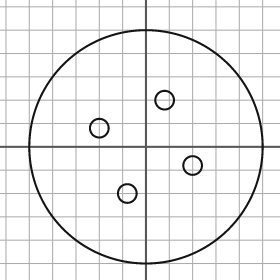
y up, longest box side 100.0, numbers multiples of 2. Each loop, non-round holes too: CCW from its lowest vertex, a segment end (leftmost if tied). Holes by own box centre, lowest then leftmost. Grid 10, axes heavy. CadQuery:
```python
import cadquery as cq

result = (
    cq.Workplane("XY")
    .moveTo(0.0, 0.0)
    .circle(50.0)
    .moveTo(-8.0, -20.0)
    .circle(4.0)
    .moveTo(20.0, -8.0)
    .circle(4.0)
    .moveTo(-20.0, 8.0)
    .circle(4.0)
    .moveTo(8.0, 20.0)
    .circle(4.0)
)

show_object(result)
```